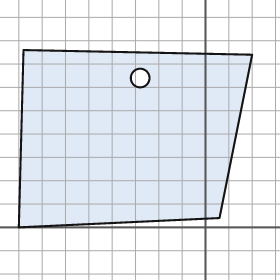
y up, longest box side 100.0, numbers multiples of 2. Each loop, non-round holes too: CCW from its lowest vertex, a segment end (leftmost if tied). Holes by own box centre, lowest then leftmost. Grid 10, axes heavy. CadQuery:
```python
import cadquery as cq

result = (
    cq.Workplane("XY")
    .moveTo(-80.0, 0.0)
    .lineTo(6.0, 4.0)
    .lineTo(20.0, 74.0)
    .lineTo(-78.0, 76.0)
    .close()
    .moveTo(-28.0, 64.0)
    .circle(4.0)
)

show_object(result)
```